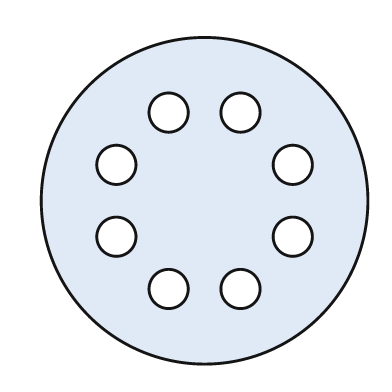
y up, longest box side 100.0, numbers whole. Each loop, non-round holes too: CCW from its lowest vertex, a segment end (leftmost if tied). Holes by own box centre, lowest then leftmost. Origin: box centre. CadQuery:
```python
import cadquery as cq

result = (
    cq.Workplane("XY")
    .moveTo(0.0, 0.0)
    .circle(50.0)
    .moveTo(-11.0, -27.0)
    .circle(6.0)
    .moveTo(11.0, -27.0)
    .circle(6.0)
    .moveTo(-27.0, -11.0)
    .circle(6.0)
    .moveTo(27.0, -11.0)
    .circle(6.0)
    .moveTo(-27.0, 11.0)
    .circle(6.0)
    .moveTo(27.0, 11.0)
    .circle(6.0)
    .moveTo(-11.0, 27.0)
    .circle(6.0)
    .moveTo(11.0, 27.0)
    .circle(6.0)
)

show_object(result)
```